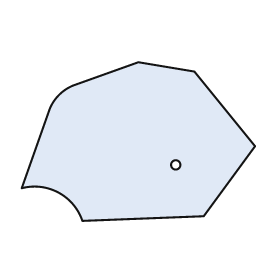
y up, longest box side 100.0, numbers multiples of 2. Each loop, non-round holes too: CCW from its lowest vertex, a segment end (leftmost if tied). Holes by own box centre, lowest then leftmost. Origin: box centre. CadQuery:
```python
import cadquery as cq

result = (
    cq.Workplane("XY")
    .moveTo(-24.0, -34.0)
    .lineTo(28.0, -32.0)
    .lineTo(50.0, -2.0)
    .lineTo(24.0, 30.0)
    .lineTo(0.0, 34.0)
    .lineTo(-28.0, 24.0)
    .threePointArc((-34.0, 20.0), (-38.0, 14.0))
    .lineTo(-50.0, -20.0)
    .threePointArc((-34.0, -22.0), (-24.0, -34.0))
    .close()
    .moveTo(16.0, -10.0)
    .circle(2.0)
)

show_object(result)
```